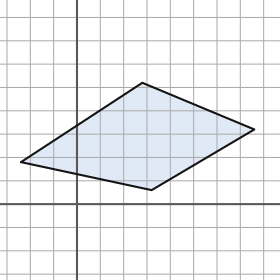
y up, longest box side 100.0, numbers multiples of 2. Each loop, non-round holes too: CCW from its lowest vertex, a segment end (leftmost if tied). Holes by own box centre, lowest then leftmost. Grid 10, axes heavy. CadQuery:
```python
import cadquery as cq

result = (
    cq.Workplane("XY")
    .moveTo(32.0, 6.0)
    .lineTo(76.0, 32.0)
    .lineTo(28.0, 52.0)
    .lineTo(-24.0, 18.0)
    .close()
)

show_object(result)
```